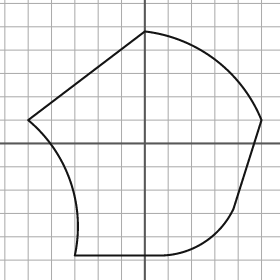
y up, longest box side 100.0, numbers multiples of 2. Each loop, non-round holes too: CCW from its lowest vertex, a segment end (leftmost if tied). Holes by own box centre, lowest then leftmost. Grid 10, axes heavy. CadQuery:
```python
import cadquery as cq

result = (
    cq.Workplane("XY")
    .moveTo(-30.0, -48.0)
    .lineTo(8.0, -48.0)
    .threePointArc((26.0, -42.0), (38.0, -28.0))
    .lineTo(50.0, 10.0)
    .threePointArc((30.0, 36.0), (0.0, 48.0))
    .lineTo(-50.0, 10.0)
    .threePointArc((-32.0, -16.0), (-30.0, -48.0))
    .close()
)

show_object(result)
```